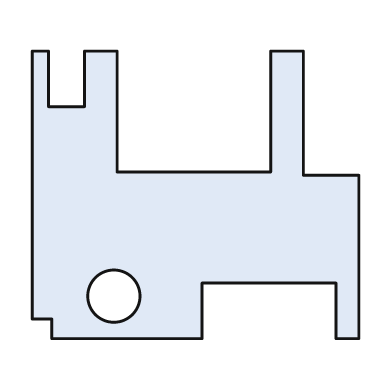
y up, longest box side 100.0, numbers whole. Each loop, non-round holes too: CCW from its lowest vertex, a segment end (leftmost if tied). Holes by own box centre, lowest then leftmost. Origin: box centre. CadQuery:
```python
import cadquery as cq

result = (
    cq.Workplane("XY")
    .moveTo(-44.0, -44.0)
    .lineTo(2.0, -44.0)
    .lineTo(2.0, -27.0)
    .lineTo(43.0, -27.0)
    .lineTo(43.0, -44.0)
    .lineTo(50.0, -44.0)
    .lineTo(50.0, 6.0)
    .lineTo(33.0, 6.0)
    .lineTo(33.0, 44.0)
    .lineTo(23.0, 44.0)
    .lineTo(23.0, 7.0)
    .lineTo(-24.0, 7.0)
    .lineTo(-24.0, 44.0)
    .lineTo(-34.0, 44.0)
    .lineTo(-34.0, 27.0)
    .lineTo(-45.0, 27.0)
    .lineTo(-45.0, 44.0)
    .lineTo(-50.0, 44.0)
    .lineTo(-50.0, -38.0)
    .lineTo(-44.0, -38.0)
    .close()
    .moveTo(-25.0, -31.0)
    .circle(8.0)
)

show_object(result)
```